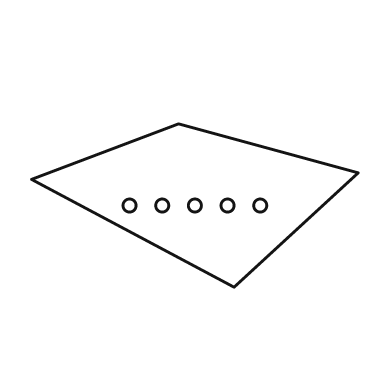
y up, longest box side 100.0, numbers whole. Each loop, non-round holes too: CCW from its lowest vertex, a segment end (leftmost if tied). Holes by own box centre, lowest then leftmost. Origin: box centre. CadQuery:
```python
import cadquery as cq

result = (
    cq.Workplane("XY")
    .moveTo(12.0, -25.0)
    .lineTo(50.0, 10.0)
    .lineTo(-5.0, 25.0)
    .lineTo(-50.0, 8.0)
    .close()
    .moveTo(-20.0, 0.0)
    .circle(2.0)
    .moveTo(-10.0, 0.0)
    .circle(2.0)
    .moveTo(0.0, 0.0)
    .circle(2.0)
    .moveTo(10.0, 0.0)
    .circle(2.0)
    .moveTo(20.0, 0.0)
    .circle(2.0)
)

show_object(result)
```